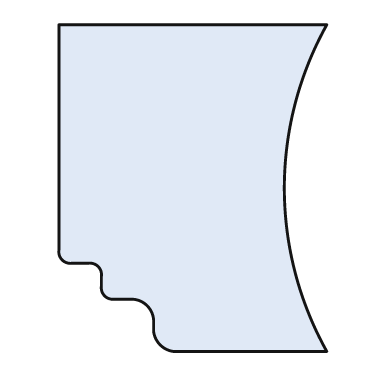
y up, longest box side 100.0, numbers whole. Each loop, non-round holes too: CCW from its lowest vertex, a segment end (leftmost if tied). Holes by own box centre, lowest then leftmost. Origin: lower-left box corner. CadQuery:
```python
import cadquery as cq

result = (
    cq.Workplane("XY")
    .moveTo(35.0, 0.0)
    .lineTo(82.0, 0.0)
    .threePointArc((69.0, 50.0), (82.0, 100.0))
    .lineTo(0.0, 100.0)
    .lineTo(0.0, 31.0)
    .threePointArc((1.0, 28.0), (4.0, 27.0))
    .lineTo(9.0, 27.0)
    .threePointArc((12.0, 26.0), (13.0, 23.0))
    .lineTo(13.0, 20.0)
    .threePointArc((14.0, 17.0), (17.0, 16.0))
    .lineTo(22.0, 16.0)
    .threePointArc((27.0, 14.0), (29.0, 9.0))
    .lineTo(29.0, 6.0)
    .threePointArc((31.0, 2.0), (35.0, 0.0))
    .close()
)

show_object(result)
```